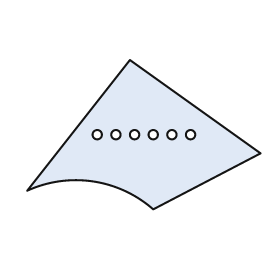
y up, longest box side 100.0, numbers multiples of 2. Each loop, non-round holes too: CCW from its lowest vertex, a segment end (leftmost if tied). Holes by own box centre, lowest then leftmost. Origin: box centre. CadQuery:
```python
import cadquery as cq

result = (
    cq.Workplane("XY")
    .moveTo(4.0, -32.0)
    .lineTo(50.0, -8.0)
    .lineTo(-6.0, 32.0)
    .lineTo(-50.0, -24.0)
    .threePointArc((-22.0, -20.0), (4.0, -32.0))
    .close()
    .moveTo(-20.0, 0.0)
    .circle(2.0)
    .moveTo(-12.0, 0.0)
    .circle(2.0)
    .moveTo(-4.0, 0.0)
    .circle(2.0)
    .moveTo(4.0, 0.0)
    .circle(2.0)
    .moveTo(12.0, 0.0)
    .circle(2.0)
    .moveTo(20.0, 0.0)
    .circle(2.0)
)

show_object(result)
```